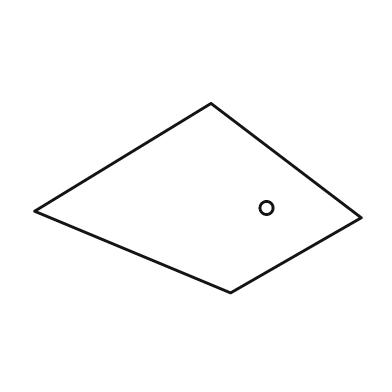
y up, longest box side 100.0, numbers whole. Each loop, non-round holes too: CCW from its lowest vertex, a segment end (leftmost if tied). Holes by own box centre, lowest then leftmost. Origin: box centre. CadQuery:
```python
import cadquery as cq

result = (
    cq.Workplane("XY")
    .moveTo(10.0, -29.0)
    .lineTo(50.0, -6.0)
    .lineTo(4.0, 29.0)
    .lineTo(-50.0, -4.0)
    .close()
    .moveTo(21.0, -3.0)
    .circle(2.0)
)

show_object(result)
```